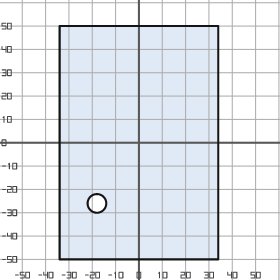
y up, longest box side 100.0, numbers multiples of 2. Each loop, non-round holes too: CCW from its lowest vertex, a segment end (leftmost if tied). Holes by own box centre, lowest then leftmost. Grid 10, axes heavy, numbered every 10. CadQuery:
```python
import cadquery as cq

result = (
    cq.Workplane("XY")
    .moveTo(-34.0, -50.0)
    .lineTo(34.0, -50.0)
    .lineTo(34.0, 50.0)
    .lineTo(-34.0, 50.0)
    .close()
    .moveTo(-18.0, -26.0)
    .circle(4.0)
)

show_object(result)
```